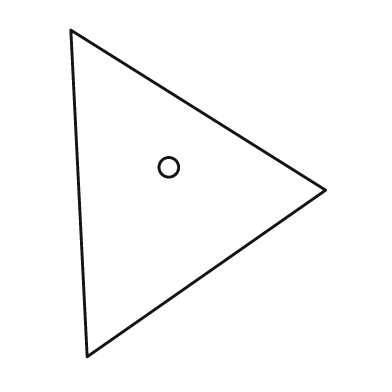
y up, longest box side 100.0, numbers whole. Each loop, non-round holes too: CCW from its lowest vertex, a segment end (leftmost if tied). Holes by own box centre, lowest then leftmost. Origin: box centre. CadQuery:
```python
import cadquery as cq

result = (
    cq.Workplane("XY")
    .moveTo(-34.0, -50.0)
    .lineTo(39.0, 1.0)
    .lineTo(-39.0, 50.0)
    .close()
    .moveTo(-9.0, 8.0)
    .circle(3.0)
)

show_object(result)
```